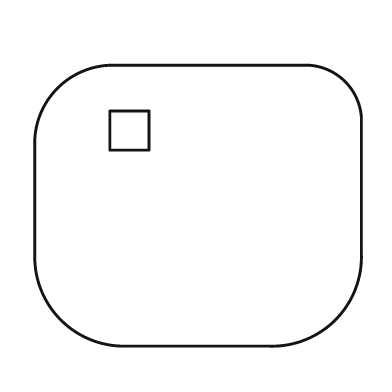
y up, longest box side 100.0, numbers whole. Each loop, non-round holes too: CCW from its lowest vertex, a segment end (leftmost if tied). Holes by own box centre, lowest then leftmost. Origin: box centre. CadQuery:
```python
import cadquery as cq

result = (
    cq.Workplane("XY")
    .moveTo(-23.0, -43.0)
    .lineTo(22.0, -43.0)
    .threePointArc((42.0, -35.0), (50.0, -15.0))
    .lineTo(50.0, 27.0)
    .threePointArc((45.0, 38.0), (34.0, 43.0))
    .lineTo(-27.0, 43.0)
    .threePointArc((-43.0, 36.0), (-50.0, 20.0))
    .lineTo(-50.0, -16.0)
    .threePointArc((-42.0, -35.0), (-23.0, -43.0))
    .close()
    .moveTo(-27.0, 17.0)
    .lineTo(-15.0, 17.0)
    .lineTo(-15.0, 29.0)
    .lineTo(-27.0, 29.0)
    .close()
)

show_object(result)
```